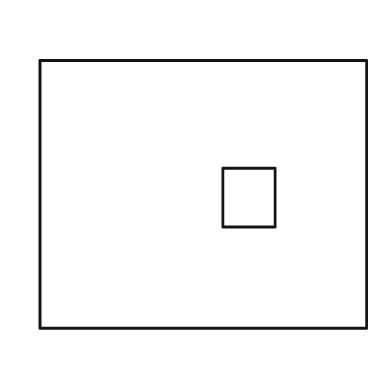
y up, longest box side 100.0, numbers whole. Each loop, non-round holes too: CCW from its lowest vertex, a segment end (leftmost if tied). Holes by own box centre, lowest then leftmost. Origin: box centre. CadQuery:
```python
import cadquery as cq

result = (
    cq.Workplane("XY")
    .moveTo(-50.0, -41.0)
    .lineTo(50.0, -41.0)
    .lineTo(50.0, 41.0)
    .lineTo(-50.0, 41.0)
    .close()
    .moveTo(6.0, -10.0)
    .lineTo(22.0, -10.0)
    .lineTo(22.0, 8.0)
    .lineTo(6.0, 8.0)
    .close()
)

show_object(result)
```